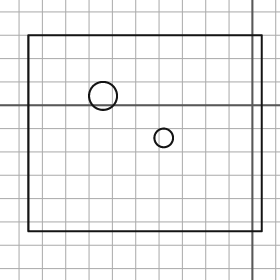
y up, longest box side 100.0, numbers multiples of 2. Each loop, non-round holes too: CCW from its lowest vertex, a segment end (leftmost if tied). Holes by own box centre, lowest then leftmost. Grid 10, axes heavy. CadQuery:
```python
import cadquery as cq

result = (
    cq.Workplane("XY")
    .moveTo(-96.0, -54.0)
    .lineTo(4.0, -54.0)
    .lineTo(4.0, 30.0)
    .lineTo(-96.0, 30.0)
    .close()
    .moveTo(-38.0, -14.0)
    .circle(4.0)
    .moveTo(-64.0, 4.0)
    .circle(6.0)
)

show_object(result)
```